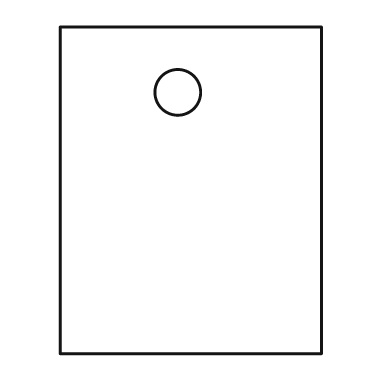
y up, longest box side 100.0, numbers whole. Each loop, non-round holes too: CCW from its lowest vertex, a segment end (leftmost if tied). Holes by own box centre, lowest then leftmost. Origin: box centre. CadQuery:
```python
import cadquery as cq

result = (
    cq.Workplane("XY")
    .moveTo(-40.0, -50.0)
    .lineTo(40.0, -50.0)
    .lineTo(40.0, 50.0)
    .lineTo(-40.0, 50.0)
    .close()
    .moveTo(-4.0, 30.0)
    .circle(7.0)
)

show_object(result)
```